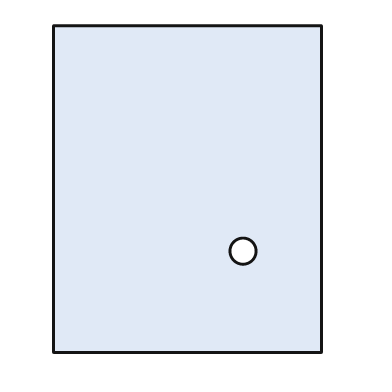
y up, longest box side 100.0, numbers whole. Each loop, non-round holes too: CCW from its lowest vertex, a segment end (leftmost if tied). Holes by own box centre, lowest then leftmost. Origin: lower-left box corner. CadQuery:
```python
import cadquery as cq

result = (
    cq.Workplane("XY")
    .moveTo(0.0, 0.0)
    .lineTo(82.0, 0.0)
    .lineTo(82.0, 100.0)
    .lineTo(0.0, 100.0)
    .close()
    .moveTo(58.0, 31.0)
    .circle(4.0)
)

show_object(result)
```